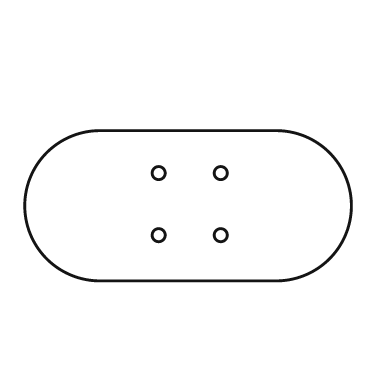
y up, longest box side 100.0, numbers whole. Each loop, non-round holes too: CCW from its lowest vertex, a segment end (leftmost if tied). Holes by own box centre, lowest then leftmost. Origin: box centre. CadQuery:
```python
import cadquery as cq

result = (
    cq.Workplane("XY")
    .moveTo(-27.0, -23.0)
    .lineTo(27.0, -23.0)
    .threePointArc((50.0, 0.0), (27.0, 23.0))
    .lineTo(-27.0, 23.0)
    .threePointArc((-50.0, 0.0), (-27.0, -23.0))
    .close()
    .moveTo(-9.0, -9.0)
    .circle(2.0)
    .moveTo(10.0, -9.0)
    .circle(2.0)
    .moveTo(-9.0, 10.0)
    .circle(2.0)
    .moveTo(10.0, 10.0)
    .circle(2.0)
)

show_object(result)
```